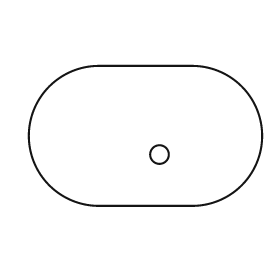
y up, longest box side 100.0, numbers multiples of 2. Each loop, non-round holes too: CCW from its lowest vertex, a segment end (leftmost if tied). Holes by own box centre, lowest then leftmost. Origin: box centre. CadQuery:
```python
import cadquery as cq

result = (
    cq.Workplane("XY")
    .moveTo(-20.0, -30.0)
    .lineTo(20.0, -30.0)
    .threePointArc((50.0, 0.0), (20.0, 30.0))
    .lineTo(-20.0, 30.0)
    .threePointArc((-50.0, 0.0), (-20.0, -30.0))
    .close()
    .moveTo(6.0, -8.0)
    .circle(4.0)
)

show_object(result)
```